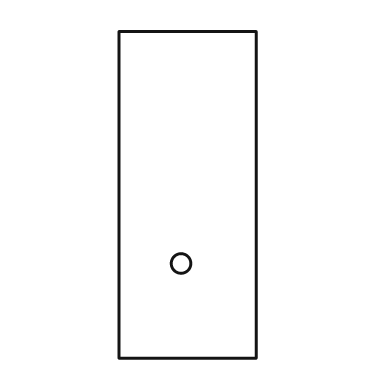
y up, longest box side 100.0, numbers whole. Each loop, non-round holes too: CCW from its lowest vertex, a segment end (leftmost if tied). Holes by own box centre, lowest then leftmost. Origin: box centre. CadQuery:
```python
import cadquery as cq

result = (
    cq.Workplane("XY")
    .moveTo(-21.0, -50.0)
    .lineTo(21.0, -50.0)
    .lineTo(21.0, 50.0)
    .lineTo(-21.0, 50.0)
    .close()
    .moveTo(-2.0, -21.0)
    .circle(3.0)
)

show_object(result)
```